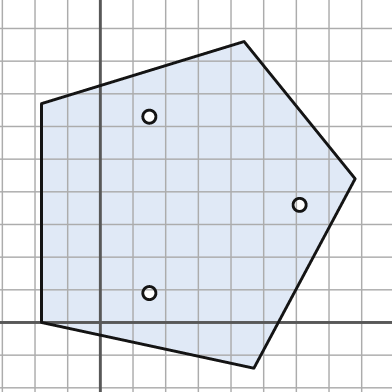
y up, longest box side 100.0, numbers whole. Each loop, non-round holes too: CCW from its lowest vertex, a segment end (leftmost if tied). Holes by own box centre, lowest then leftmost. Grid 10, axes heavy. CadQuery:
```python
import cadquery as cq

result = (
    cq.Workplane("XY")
    .moveTo(47.0, -14.0)
    .lineTo(78.0, 44.0)
    .lineTo(44.0, 86.0)
    .lineTo(-18.0, 67.0)
    .lineTo(-18.0, 0.0)
    .close()
    .moveTo(15.0, 9.0)
    .circle(2.0)
    .moveTo(61.0, 36.0)
    .circle(2.0)
    .moveTo(15.0, 63.0)
    .circle(2.0)
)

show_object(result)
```